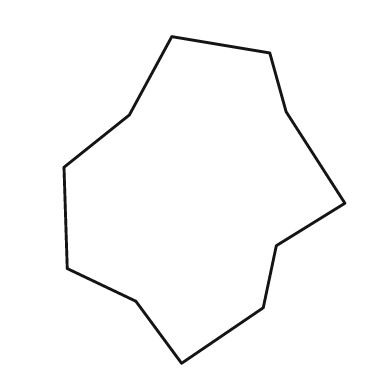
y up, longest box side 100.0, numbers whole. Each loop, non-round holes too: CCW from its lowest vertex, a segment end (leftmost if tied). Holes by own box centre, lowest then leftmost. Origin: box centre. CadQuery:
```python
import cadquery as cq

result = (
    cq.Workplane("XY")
    .moveTo(-7.0, -50.0)
    .lineTo(18.0, -33.0)
    .lineTo(22.0, -14.0)
    .lineTo(43.0, -1.0)
    .lineTo(25.0, 27.0)
    .lineTo(20.0, 45.0)
    .lineTo(-10.0, 50.0)
    .lineTo(-23.0, 26.0)
    .lineTo(-43.0, 10.0)
    .lineTo(-42.0, -21.0)
    .lineTo(-21.0, -31.0)
    .close()
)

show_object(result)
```